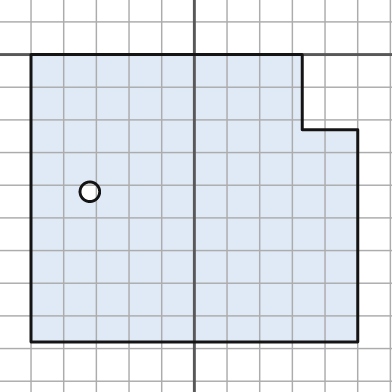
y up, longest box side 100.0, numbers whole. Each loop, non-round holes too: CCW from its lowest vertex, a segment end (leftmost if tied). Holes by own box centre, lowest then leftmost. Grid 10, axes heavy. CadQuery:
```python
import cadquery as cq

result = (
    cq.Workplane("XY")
    .moveTo(-50.0, -88.0)
    .lineTo(50.0, -88.0)
    .lineTo(50.0, -23.0)
    .lineTo(33.0, -23.0)
    .lineTo(33.0, 0.0)
    .lineTo(-50.0, 0.0)
    .close()
    .moveTo(-32.0, -42.0)
    .circle(3.0)
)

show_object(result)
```